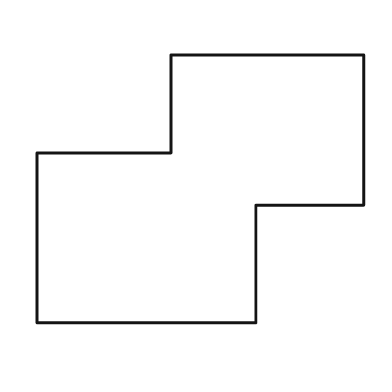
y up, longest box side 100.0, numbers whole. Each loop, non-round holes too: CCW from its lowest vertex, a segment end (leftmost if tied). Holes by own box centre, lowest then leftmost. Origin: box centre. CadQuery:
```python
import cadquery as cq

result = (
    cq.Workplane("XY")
    .moveTo(-50.0, -41.0)
    .lineTo(17.0, -41.0)
    .lineTo(17.0, -5.0)
    .lineTo(50.0, -5.0)
    .lineTo(50.0, 41.0)
    .lineTo(-9.0, 41.0)
    .lineTo(-9.0, 11.0)
    .lineTo(-50.0, 11.0)
    .close()
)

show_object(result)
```